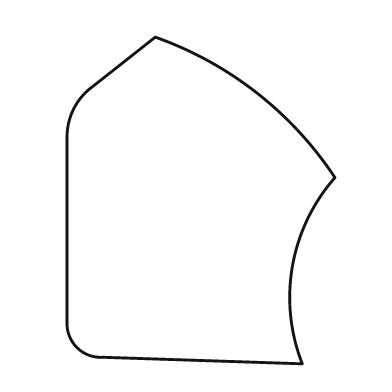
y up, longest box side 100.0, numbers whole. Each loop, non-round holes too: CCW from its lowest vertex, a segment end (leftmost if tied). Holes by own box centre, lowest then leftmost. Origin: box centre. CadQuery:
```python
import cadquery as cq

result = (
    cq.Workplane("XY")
    .moveTo(31.0, -50.0)
    .threePointArc((28.0, -20.0), (41.0, 7.0))
    .threePointArc((17.0, 33.0), (-14.0, 50.0))
    .lineTo(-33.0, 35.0)
    .threePointArc((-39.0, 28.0), (-41.0, 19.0))
    .lineTo(-41.0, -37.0)
    .threePointArc((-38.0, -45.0), (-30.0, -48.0))
    .close()
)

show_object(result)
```